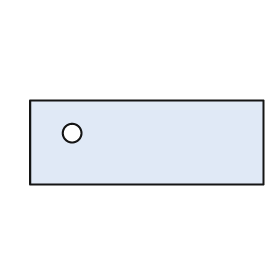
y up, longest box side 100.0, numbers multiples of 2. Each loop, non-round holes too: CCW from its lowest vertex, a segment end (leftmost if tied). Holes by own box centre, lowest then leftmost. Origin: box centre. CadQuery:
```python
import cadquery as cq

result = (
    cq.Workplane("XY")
    .moveTo(-50.0, -18.0)
    .lineTo(50.0, -18.0)
    .lineTo(50.0, 18.0)
    .lineTo(-50.0, 18.0)
    .close()
    .moveTo(-32.0, 4.0)
    .circle(4.0)
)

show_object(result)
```